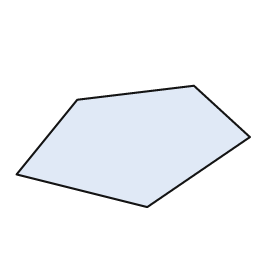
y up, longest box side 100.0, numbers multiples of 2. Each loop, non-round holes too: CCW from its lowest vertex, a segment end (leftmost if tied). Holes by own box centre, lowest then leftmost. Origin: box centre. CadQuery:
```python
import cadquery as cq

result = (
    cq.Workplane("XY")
    .moveTo(6.0, -26.0)
    .lineTo(50.0, 4.0)
    .lineTo(26.0, 26.0)
    .lineTo(-24.0, 20.0)
    .lineTo(-50.0, -12.0)
    .close()
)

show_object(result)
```